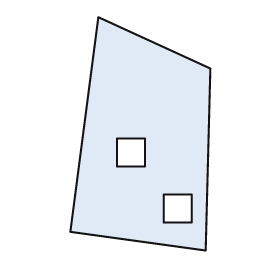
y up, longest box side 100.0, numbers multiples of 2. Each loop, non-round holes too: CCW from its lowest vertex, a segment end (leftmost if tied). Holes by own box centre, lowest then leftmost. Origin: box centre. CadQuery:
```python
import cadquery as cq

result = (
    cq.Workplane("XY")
    .moveTo(28.0, -50.0)
    .lineTo(30.0, 28.0)
    .lineTo(-18.0, 50.0)
    .lineTo(-30.0, -42.0)
    .close()
    .moveTo(10.0, -38.0)
    .lineTo(22.0, -38.0)
    .lineTo(22.0, -26.0)
    .lineTo(10.0, -26.0)
    .close()
    .moveTo(-10.0, -14.0)
    .lineTo(2.0, -14.0)
    .lineTo(2.0, -2.0)
    .lineTo(-10.0, -2.0)
    .close()
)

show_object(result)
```